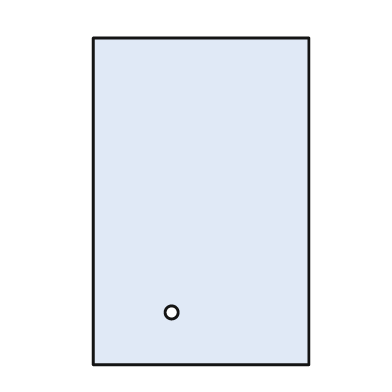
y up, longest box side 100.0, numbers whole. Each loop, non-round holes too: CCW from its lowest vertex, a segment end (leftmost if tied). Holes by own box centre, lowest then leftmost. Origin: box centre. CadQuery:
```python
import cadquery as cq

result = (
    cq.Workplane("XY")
    .moveTo(-33.0, -50.0)
    .lineTo(33.0, -50.0)
    .lineTo(33.0, 50.0)
    .lineTo(-33.0, 50.0)
    .close()
    .moveTo(-9.0, -34.0)
    .circle(2.0)
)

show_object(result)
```